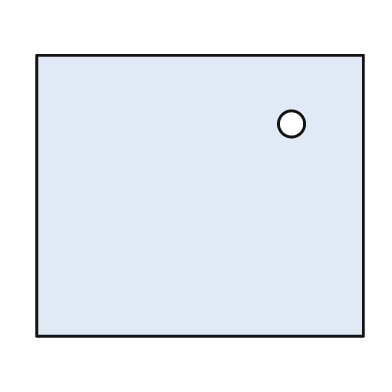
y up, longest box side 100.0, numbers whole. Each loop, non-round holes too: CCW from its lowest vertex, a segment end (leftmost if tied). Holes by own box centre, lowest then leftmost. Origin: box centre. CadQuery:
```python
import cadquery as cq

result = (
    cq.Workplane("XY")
    .moveTo(-50.0, -43.0)
    .lineTo(50.0, -43.0)
    .lineTo(50.0, 43.0)
    .lineTo(-50.0, 43.0)
    .close()
    .moveTo(28.0, 22.0)
    .circle(4.0)
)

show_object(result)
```